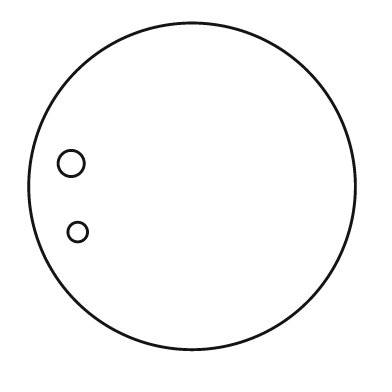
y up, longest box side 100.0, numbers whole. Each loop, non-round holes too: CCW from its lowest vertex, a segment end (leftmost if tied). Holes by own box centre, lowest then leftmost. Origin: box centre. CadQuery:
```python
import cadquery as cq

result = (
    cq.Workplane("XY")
    .moveTo(0.0, 0.0)
    .circle(50.0)
    .moveTo(-35.0, -14.0)
    .circle(3.0)
    .moveTo(-37.0, 7.0)
    .circle(4.0)
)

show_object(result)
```